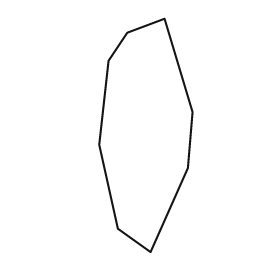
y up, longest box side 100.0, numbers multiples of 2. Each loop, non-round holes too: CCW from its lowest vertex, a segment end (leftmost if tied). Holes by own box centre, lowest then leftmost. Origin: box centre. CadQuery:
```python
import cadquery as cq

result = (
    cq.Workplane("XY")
    .moveTo(2.0, -50.0)
    .lineTo(18.0, -14.0)
    .lineTo(20.0, 10.0)
    .lineTo(8.0, 50.0)
    .lineTo(-8.0, 44.0)
    .lineTo(-16.0, 32.0)
    .lineTo(-20.0, -4.0)
    .lineTo(-12.0, -40.0)
    .close()
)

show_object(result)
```